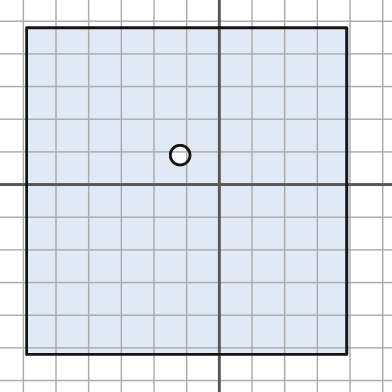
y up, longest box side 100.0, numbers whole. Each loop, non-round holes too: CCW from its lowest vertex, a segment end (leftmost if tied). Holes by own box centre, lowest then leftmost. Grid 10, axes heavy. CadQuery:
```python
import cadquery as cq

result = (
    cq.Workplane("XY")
    .moveTo(-59.0, -52.0)
    .lineTo(39.0, -52.0)
    .lineTo(39.0, 48.0)
    .lineTo(-59.0, 48.0)
    .close()
    .moveTo(-12.0, 9.0)
    .circle(3.0)
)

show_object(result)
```